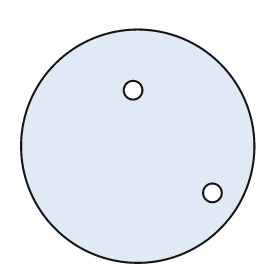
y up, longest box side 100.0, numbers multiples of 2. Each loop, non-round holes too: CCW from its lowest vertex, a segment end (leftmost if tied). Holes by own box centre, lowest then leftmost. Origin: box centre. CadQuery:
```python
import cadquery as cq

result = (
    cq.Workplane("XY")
    .moveTo(0.0, 0.0)
    .circle(50.0)
    .moveTo(32.0, -20.0)
    .circle(4.0)
    .moveTo(-2.0, 24.0)
    .circle(4.0)
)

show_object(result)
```